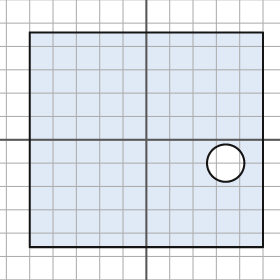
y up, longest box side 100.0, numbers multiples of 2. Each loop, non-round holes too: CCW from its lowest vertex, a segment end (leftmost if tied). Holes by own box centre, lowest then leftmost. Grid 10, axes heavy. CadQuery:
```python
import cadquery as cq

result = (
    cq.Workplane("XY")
    .moveTo(-50.0, -46.0)
    .lineTo(50.0, -46.0)
    .lineTo(50.0, 46.0)
    .lineTo(-50.0, 46.0)
    .close()
    .moveTo(34.0, -10.0)
    .circle(8.0)
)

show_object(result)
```